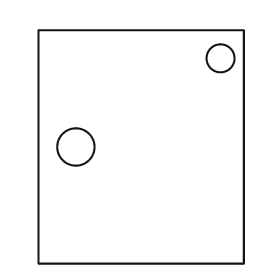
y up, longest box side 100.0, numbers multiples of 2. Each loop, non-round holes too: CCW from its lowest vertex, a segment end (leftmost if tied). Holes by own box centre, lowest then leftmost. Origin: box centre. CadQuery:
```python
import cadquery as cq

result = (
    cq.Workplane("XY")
    .moveTo(-44.0, -50.0)
    .lineTo(44.0, -50.0)
    .lineTo(44.0, 50.0)
    .lineTo(-44.0, 50.0)
    .close()
    .moveTo(-28.0, 0.0)
    .circle(8.0)
    .moveTo(34.0, 38.0)
    .circle(6.0)
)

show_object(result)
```